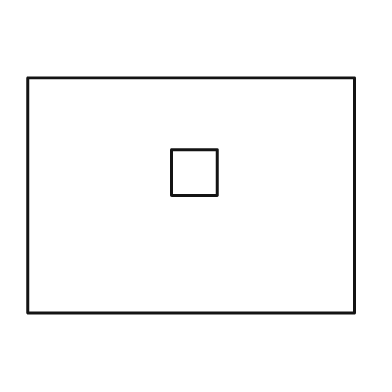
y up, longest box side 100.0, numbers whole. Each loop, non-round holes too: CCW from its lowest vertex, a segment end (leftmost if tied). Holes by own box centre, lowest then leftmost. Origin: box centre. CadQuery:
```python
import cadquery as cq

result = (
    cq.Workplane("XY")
    .moveTo(-50.0, -36.0)
    .lineTo(50.0, -36.0)
    .lineTo(50.0, 36.0)
    .lineTo(-50.0, 36.0)
    .close()
    .moveTo(-6.0, 0.0)
    .lineTo(8.0, 0.0)
    .lineTo(8.0, 14.0)
    .lineTo(-6.0, 14.0)
    .close()
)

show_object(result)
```